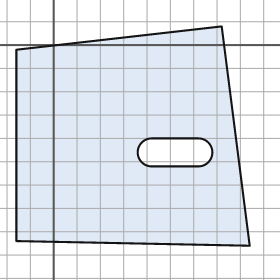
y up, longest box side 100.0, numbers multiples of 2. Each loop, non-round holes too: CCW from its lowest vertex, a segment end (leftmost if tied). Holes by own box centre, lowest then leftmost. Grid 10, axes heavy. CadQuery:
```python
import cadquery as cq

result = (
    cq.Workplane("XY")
    .moveTo(84.0, -86.0)
    .lineTo(72.0, 8.0)
    .lineTo(-16.0, -2.0)
    .lineTo(-16.0, -84.0)
    .close()
    .moveTo(42.0, -52.0)
    .lineTo(62.0, -52.0)
    .threePointArc((68.0, -46.0), (62.0, -40.0))
    .lineTo(42.0, -40.0)
    .threePointArc((36.0, -46.0), (42.0, -52.0))
    .close()
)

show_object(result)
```